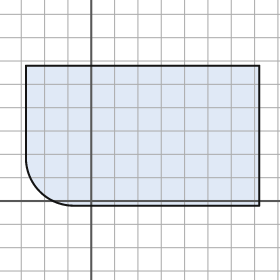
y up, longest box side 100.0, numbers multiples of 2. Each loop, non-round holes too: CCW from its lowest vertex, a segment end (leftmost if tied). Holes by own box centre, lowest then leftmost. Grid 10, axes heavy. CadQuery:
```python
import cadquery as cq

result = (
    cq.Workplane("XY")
    .moveTo(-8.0, -2.0)
    .lineTo(72.0, -2.0)
    .lineTo(72.0, 58.0)
    .lineTo(-28.0, 58.0)
    .lineTo(-28.0, 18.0)
    .threePointArc((-22.0, 4.0), (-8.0, -2.0))
    .close()
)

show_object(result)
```